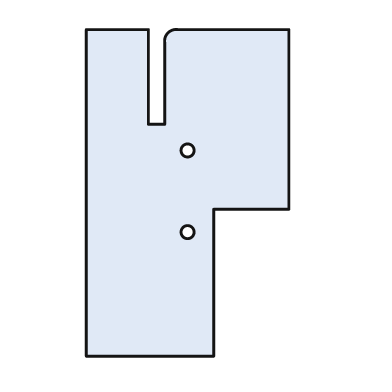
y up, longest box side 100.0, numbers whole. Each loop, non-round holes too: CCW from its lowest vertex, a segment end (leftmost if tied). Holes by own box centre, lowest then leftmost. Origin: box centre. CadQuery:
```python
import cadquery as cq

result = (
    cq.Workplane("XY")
    .moveTo(-31.0, -50.0)
    .lineTo(8.0, -50.0)
    .lineTo(8.0, -5.0)
    .lineTo(31.0, -5.0)
    .lineTo(31.0, 50.0)
    .lineTo(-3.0, 50.0)
    .threePointArc((-6.0, 49.0), (-7.0, 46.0))
    .lineTo(-7.0, 21.0)
    .lineTo(-12.0, 21.0)
    .lineTo(-12.0, 50.0)
    .lineTo(-31.0, 50.0)
    .close()
    .moveTo(0.0, -12.0)
    .circle(2.0)
    .moveTo(0.0, 13.0)
    .circle(2.0)
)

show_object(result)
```